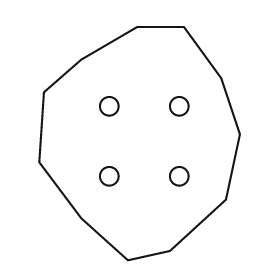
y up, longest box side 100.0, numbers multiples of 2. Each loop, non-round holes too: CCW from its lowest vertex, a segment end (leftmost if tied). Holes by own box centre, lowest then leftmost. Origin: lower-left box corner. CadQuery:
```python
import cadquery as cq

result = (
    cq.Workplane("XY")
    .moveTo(38.0, 0.0)
    .lineTo(56.0, 4.0)
    .lineTo(80.0, 26.0)
    .lineTo(86.0, 54.0)
    .lineTo(78.0, 78.0)
    .lineTo(62.0, 100.0)
    .lineTo(42.0, 100.0)
    .lineTo(18.0, 86.0)
    .lineTo(2.0, 72.0)
    .lineTo(0.0, 42.0)
    .lineTo(18.0, 18.0)
    .close()
    .moveTo(30.0, 36.0)
    .circle(4.0)
    .moveTo(60.0, 36.0)
    .circle(4.0)
    .moveTo(30.0, 66.0)
    .circle(4.0)
    .moveTo(60.0, 66.0)
    .circle(4.0)
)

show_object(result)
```